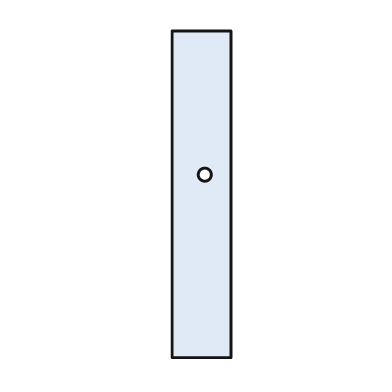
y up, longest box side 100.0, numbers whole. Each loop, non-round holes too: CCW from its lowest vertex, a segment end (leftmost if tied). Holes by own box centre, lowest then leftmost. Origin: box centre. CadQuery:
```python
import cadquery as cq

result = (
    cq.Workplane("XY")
    .moveTo(-9.0, -50.0)
    .lineTo(9.0, -50.0)
    .lineTo(9.0, 50.0)
    .lineTo(-9.0, 50.0)
    .close()
    .moveTo(1.0, 6.0)
    .circle(2.0)
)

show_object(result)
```